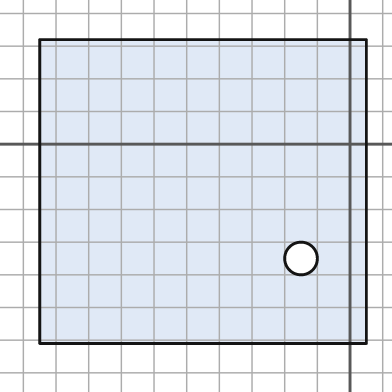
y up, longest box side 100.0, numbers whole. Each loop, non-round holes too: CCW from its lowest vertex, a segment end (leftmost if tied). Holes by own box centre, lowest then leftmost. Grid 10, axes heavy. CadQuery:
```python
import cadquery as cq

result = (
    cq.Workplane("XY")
    .moveTo(-95.0, -61.0)
    .lineTo(5.0, -61.0)
    .lineTo(5.0, 32.0)
    .lineTo(-95.0, 32.0)
    .close()
    .moveTo(-15.0, -35.0)
    .circle(5.0)
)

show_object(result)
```